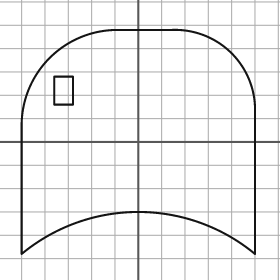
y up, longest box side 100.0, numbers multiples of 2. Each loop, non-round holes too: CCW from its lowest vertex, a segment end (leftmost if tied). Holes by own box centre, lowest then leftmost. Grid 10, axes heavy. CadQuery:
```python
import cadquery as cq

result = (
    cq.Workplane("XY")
    .moveTo(-50.0, -48.0)
    .threePointArc((0.0, -30.0), (50.0, -48.0))
    .lineTo(50.0, 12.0)
    .threePointArc((40.0, 38.0), (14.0, 48.0))
    .lineTo(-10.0, 48.0)
    .threePointArc((-38.0, 36.0), (-50.0, 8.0))
    .close()
    .moveTo(-36.0, 16.0)
    .lineTo(-28.0, 16.0)
    .lineTo(-28.0, 28.0)
    .lineTo(-36.0, 28.0)
    .close()
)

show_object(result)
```